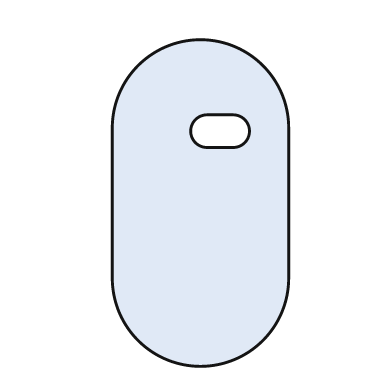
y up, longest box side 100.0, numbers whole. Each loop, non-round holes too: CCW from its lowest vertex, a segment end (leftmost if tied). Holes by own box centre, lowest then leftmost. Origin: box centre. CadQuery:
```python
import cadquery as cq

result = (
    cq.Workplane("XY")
    .moveTo(-27.0, -23.0)
    .threePointArc((0.0, -50.0), (27.0, -23.0))
    .lineTo(27.0, 23.0)
    .threePointArc((0.0, 50.0), (-27.0, 23.0))
    .close()
    .moveTo(2.0, 17.0)
    .lineTo(10.0, 17.0)
    .threePointArc((15.0, 22.0), (10.0, 27.0))
    .lineTo(2.0, 27.0)
    .threePointArc((-3.0, 22.0), (2.0, 17.0))
    .close()
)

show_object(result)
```